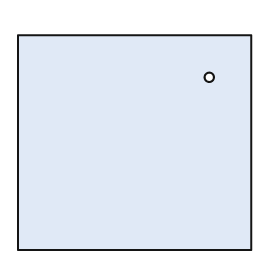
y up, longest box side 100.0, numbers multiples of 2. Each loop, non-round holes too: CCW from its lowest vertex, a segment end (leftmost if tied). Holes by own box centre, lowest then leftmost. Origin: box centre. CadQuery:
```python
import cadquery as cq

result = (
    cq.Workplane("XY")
    .moveTo(-50.0, -46.0)
    .lineTo(50.0, -46.0)
    .lineTo(50.0, 46.0)
    .lineTo(-50.0, 46.0)
    .close()
    .moveTo(32.0, 28.0)
    .circle(2.0)
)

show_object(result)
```